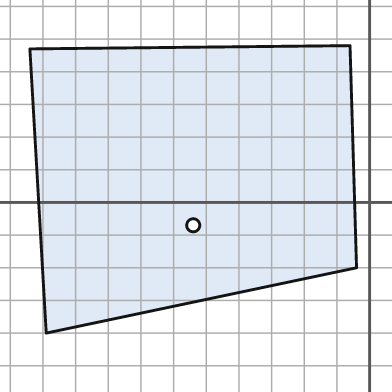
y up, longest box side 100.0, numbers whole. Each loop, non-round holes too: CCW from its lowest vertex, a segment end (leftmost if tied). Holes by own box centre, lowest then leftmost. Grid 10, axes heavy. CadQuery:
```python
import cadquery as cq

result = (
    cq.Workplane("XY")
    .moveTo(-99.0, -40.0)
    .lineTo(-4.0, -20.0)
    .lineTo(-6.0, 48.0)
    .lineTo(-104.0, 47.0)
    .close()
    .moveTo(-54.0, -7.0)
    .circle(2.0)
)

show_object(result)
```